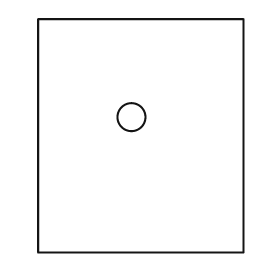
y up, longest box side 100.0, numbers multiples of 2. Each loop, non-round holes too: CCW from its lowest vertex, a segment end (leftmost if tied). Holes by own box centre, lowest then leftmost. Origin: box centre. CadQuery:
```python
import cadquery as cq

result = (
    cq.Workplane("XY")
    .moveTo(-44.0, -50.0)
    .lineTo(44.0, -50.0)
    .lineTo(44.0, 50.0)
    .lineTo(-44.0, 50.0)
    .close()
    .moveTo(-4.0, 8.0)
    .circle(6.0)
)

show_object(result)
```